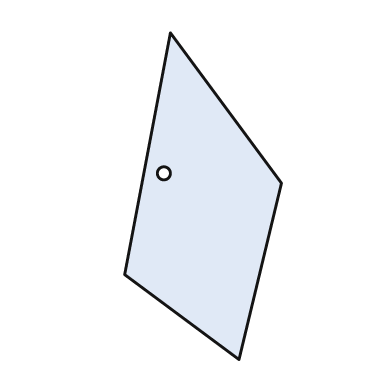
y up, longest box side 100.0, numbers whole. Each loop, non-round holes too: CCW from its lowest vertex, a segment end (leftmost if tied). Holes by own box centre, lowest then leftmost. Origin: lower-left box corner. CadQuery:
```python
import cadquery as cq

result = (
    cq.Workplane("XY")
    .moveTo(35.0, 0.0)
    .lineTo(48.0, 54.0)
    .lineTo(14.0, 100.0)
    .lineTo(0.0, 26.0)
    .close()
    .moveTo(12.0, 57.0)
    .circle(2.0)
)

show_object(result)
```